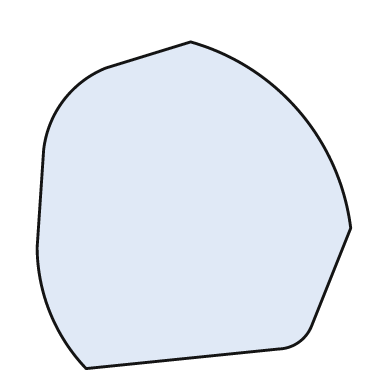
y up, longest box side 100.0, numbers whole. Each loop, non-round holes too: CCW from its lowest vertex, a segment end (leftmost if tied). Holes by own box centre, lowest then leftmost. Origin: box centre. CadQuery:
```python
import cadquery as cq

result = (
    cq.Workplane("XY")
    .moveTo(-33.0, -50.0)
    .lineTo(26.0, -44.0)
    .threePointArc((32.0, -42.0), (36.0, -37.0))
    .lineTo(48.0, -7.0)
    .threePointArc((32.0, 29.0), (-1.0, 50.0))
    .lineTo(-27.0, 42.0)
    .threePointArc((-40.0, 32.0), (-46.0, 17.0))
    .lineTo(-48.0, -13.0)
    .threePointArc((-44.0, -33.0), (-33.0, -50.0))
    .close()
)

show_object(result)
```